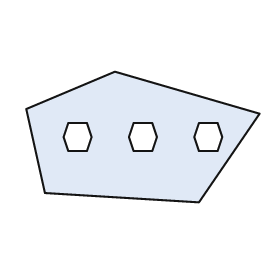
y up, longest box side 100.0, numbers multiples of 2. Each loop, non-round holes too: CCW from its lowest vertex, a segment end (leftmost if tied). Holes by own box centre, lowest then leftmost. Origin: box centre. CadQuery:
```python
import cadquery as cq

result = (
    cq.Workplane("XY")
    .moveTo(24.0, -28.0)
    .lineTo(50.0, 10.0)
    .lineTo(-12.0, 28.0)
    .lineTo(-50.0, 12.0)
    .lineTo(-42.0, -24.0)
    .close()
    .moveTo(-32.0, -6.0)
    .lineTo(-24.0, -6.0)
    .lineTo(-22.0, 0.0)
    .lineTo(-24.0, 6.0)
    .lineTo(-32.0, 6.0)
    .lineTo(-34.0, 0.0)
    .close()
    .moveTo(-4.0, -6.0)
    .lineTo(4.0, -6.0)
    .lineTo(6.0, 0.0)
    .lineTo(4.0, 6.0)
    .lineTo(-4.0, 6.0)
    .lineTo(-6.0, 0.0)
    .close()
    .moveTo(24.0, -6.0)
    .lineTo(32.0, -6.0)
    .lineTo(34.0, 0.0)
    .lineTo(32.0, 6.0)
    .lineTo(24.0, 6.0)
    .lineTo(22.0, 0.0)
    .close()
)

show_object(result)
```